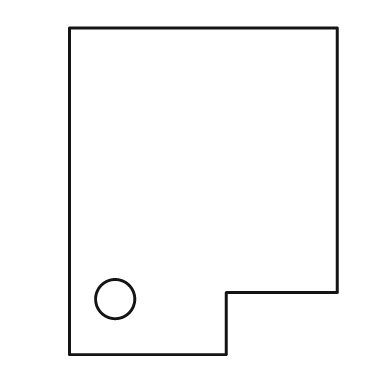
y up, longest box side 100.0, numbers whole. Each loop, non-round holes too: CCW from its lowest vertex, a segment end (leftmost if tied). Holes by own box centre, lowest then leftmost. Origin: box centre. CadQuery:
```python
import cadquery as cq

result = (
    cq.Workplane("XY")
    .moveTo(-41.0, -50.0)
    .lineTo(7.0, -50.0)
    .lineTo(7.0, -31.0)
    .lineTo(41.0, -31.0)
    .lineTo(41.0, 50.0)
    .lineTo(-41.0, 50.0)
    .close()
    .moveTo(-27.0, -33.0)
    .circle(6.0)
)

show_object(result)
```